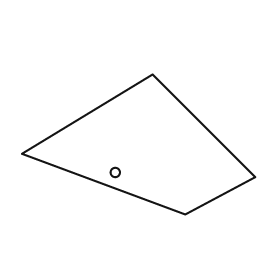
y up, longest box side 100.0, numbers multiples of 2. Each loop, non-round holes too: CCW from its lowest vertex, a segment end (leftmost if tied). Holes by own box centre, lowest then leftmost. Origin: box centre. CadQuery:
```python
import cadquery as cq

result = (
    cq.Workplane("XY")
    .moveTo(20.0, -30.0)
    .lineTo(50.0, -14.0)
    .lineTo(6.0, 30.0)
    .lineTo(-50.0, -4.0)
    .close()
    .moveTo(-10.0, -12.0)
    .circle(2.0)
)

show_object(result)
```